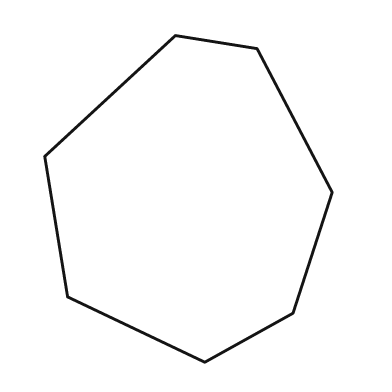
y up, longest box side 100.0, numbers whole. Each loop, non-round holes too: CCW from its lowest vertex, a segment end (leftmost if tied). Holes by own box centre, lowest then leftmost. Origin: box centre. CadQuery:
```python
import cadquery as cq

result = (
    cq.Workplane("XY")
    .moveTo(5.0, -50.0)
    .lineTo(32.0, -35.0)
    .lineTo(44.0, 2.0)
    .lineTo(21.0, 46.0)
    .lineTo(-4.0, 50.0)
    .lineTo(-44.0, 13.0)
    .lineTo(-37.0, -30.0)
    .close()
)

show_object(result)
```